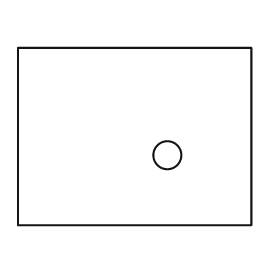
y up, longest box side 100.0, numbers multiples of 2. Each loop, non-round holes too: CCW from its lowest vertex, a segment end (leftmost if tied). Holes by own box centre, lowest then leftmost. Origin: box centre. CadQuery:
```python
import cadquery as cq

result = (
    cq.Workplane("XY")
    .moveTo(-50.0, -38.0)
    .lineTo(50.0, -38.0)
    .lineTo(50.0, 38.0)
    .lineTo(-50.0, 38.0)
    .close()
    .moveTo(14.0, -8.0)
    .circle(6.0)
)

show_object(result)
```